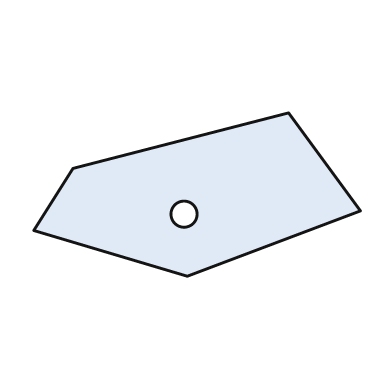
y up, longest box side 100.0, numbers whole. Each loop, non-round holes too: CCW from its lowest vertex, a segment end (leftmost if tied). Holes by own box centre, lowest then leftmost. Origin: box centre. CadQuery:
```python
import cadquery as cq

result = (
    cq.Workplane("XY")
    .moveTo(-3.0, -25.0)
    .lineTo(50.0, -5.0)
    .lineTo(28.0, 25.0)
    .lineTo(-38.0, 8.0)
    .lineTo(-50.0, -11.0)
    .close()
    .moveTo(-4.0, -6.0)
    .circle(4.0)
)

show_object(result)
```